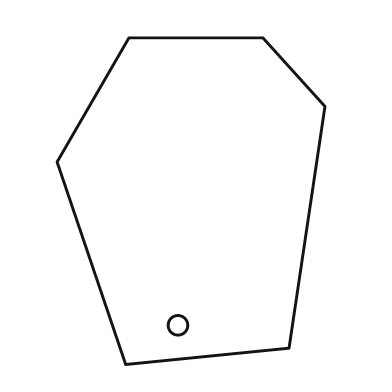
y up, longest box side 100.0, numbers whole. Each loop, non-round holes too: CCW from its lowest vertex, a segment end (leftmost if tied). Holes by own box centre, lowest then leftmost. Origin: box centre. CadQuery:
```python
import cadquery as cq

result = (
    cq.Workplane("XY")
    .moveTo(-20.0, -50.0)
    .lineTo(30.0, -45.0)
    .lineTo(41.0, 29.0)
    .lineTo(22.0, 50.0)
    .lineTo(-19.0, 50.0)
    .lineTo(-41.0, 12.0)
    .close()
    .moveTo(-4.0, -38.0)
    .circle(3.0)
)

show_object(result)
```